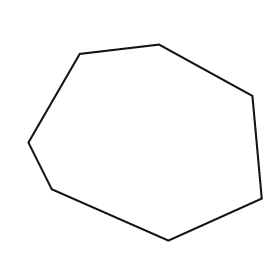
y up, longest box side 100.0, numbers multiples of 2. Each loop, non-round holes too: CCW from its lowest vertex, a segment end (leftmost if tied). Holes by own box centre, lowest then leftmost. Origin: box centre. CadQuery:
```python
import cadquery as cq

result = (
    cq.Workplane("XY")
    .moveTo(10.0, -42.0)
    .lineTo(50.0, -24.0)
    .lineTo(46.0, 20.0)
    .lineTo(6.0, 42.0)
    .lineTo(-28.0, 38.0)
    .lineTo(-50.0, 0.0)
    .lineTo(-40.0, -20.0)
    .close()
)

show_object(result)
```